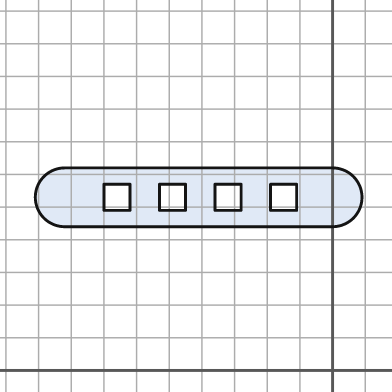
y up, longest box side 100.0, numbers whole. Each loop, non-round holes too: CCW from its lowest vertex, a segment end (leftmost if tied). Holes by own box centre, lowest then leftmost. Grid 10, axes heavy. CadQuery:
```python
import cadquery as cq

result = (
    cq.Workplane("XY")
    .moveTo(-82.0, 44.0)
    .lineTo(0.0, 44.0)
    .threePointArc((9.0, 53.0), (0.0, 62.0))
    .lineTo(-82.0, 62.0)
    .threePointArc((-91.0, 53.0), (-82.0, 44.0))
    .close()
    .moveTo(-70.0, 49.0)
    .lineTo(-62.0, 49.0)
    .lineTo(-62.0, 57.0)
    .lineTo(-70.0, 57.0)
    .close()
    .moveTo(-53.0, 49.0)
    .lineTo(-45.0, 49.0)
    .lineTo(-45.0, 57.0)
    .lineTo(-53.0, 57.0)
    .close()
    .moveTo(-36.0, 49.0)
    .lineTo(-28.0, 49.0)
    .lineTo(-28.0, 57.0)
    .lineTo(-36.0, 57.0)
    .close()
    .moveTo(-19.0, 49.0)
    .lineTo(-11.0, 49.0)
    .lineTo(-11.0, 57.0)
    .lineTo(-19.0, 57.0)
    .close()
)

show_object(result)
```